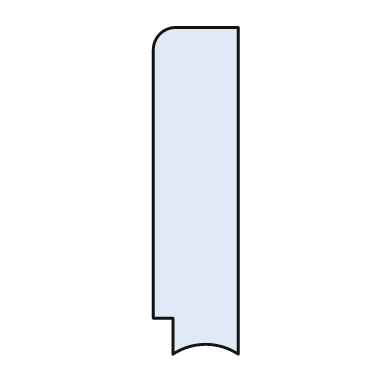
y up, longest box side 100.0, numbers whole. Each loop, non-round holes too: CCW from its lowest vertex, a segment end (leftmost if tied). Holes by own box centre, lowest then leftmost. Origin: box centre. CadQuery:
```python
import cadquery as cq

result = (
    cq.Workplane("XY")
    .moveTo(-7.0, -50.0)
    .threePointArc((3.0, -47.0), (13.0, -50.0))
    .lineTo(13.0, 50.0)
    .lineTo(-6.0, 50.0)
    .threePointArc((-11.0, 48.0), (-13.0, 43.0))
    .lineTo(-13.0, -39.0)
    .lineTo(-7.0, -39.0)
    .close()
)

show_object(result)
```